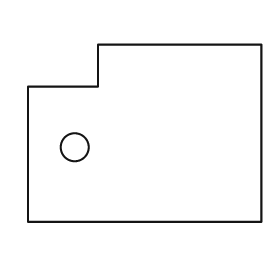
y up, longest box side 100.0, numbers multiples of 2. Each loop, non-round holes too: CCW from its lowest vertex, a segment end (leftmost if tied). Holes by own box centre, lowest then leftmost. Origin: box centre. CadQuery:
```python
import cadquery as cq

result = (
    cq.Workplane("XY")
    .moveTo(-50.0, -38.0)
    .lineTo(50.0, -38.0)
    .lineTo(50.0, 38.0)
    .lineTo(-20.0, 38.0)
    .lineTo(-20.0, 20.0)
    .lineTo(-50.0, 20.0)
    .close()
    .moveTo(-30.0, -6.0)
    .circle(6.0)
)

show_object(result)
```